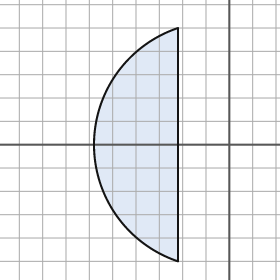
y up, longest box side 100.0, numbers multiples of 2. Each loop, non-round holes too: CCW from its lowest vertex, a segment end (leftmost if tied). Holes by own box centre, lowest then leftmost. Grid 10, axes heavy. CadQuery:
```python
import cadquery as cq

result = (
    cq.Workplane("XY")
    .moveTo(-22.0, -50.0)
    .lineTo(-22.0, 50.0)
    .threePointArc((-58.0, 0.0), (-22.0, -50.0))
    .close()
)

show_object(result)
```